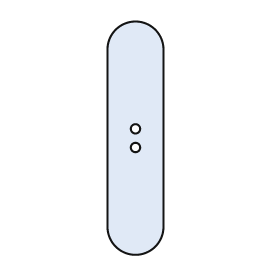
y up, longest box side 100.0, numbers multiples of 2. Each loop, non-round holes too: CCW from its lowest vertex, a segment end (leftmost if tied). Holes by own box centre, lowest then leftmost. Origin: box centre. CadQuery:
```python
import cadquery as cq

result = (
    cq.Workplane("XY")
    .moveTo(-12.0, -38.0)
    .threePointArc((0.0, -50.0), (12.0, -38.0))
    .lineTo(12.0, 38.0)
    .threePointArc((0.0, 50.0), (-12.0, 38.0))
    .close()
    .moveTo(0.0, -4.0)
    .circle(2.0)
    .moveTo(0.0, 4.0)
    .circle(2.0)
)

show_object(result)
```